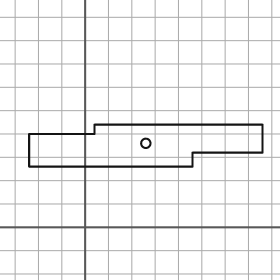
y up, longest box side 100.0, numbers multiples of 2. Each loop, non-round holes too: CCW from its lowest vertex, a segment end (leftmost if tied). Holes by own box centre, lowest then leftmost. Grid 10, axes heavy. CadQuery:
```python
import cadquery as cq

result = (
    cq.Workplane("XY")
    .moveTo(-24.0, 26.0)
    .lineTo(46.0, 26.0)
    .lineTo(46.0, 32.0)
    .lineTo(76.0, 32.0)
    .lineTo(76.0, 44.0)
    .lineTo(4.0, 44.0)
    .lineTo(4.0, 40.0)
    .lineTo(-24.0, 40.0)
    .close()
    .moveTo(26.0, 36.0)
    .circle(2.0)
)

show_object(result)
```